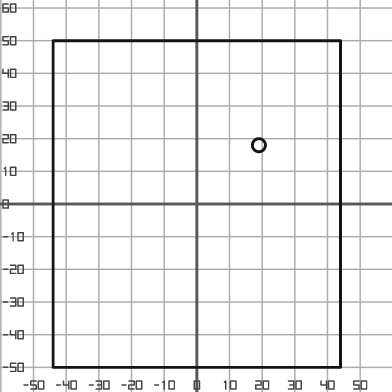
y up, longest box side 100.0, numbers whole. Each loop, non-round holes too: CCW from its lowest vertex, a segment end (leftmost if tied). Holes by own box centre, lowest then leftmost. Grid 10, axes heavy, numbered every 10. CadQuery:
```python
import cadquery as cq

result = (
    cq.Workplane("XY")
    .moveTo(-44.0, -50.0)
    .lineTo(44.0, -50.0)
    .lineTo(44.0, 50.0)
    .lineTo(-44.0, 50.0)
    .close()
    .moveTo(19.0, 18.0)
    .circle(2.0)
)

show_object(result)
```